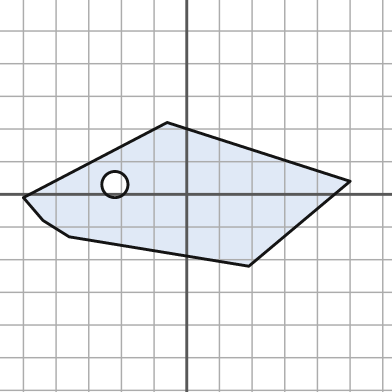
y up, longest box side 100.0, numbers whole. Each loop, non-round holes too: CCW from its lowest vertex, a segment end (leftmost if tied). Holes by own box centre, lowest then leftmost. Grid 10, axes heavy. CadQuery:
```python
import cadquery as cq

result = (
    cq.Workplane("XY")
    .moveTo(19.0, -22.0)
    .lineTo(50.0, 4.0)
    .lineTo(-6.0, 22.0)
    .lineTo(-50.0, -1.0)
    .lineTo(-44.0, -8.0)
    .lineTo(-36.0, -13.0)
    .close()
    .moveTo(-22.0, 3.0)
    .circle(4.0)
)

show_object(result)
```